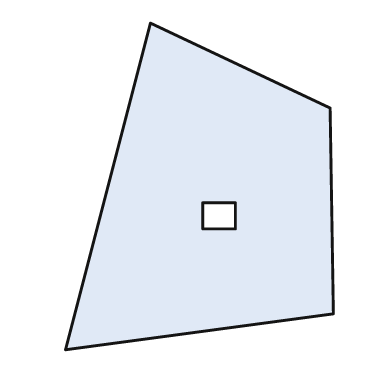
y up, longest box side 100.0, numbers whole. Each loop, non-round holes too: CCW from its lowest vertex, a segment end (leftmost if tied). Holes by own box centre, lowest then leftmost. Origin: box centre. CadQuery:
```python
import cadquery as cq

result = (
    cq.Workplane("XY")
    .moveTo(-41.0, -50.0)
    .lineTo(41.0, -39.0)
    .lineTo(40.0, 24.0)
    .lineTo(-15.0, 50.0)
    .close()
    .moveTo(1.0, -13.0)
    .lineTo(11.0, -13.0)
    .lineTo(11.0, -5.0)
    .lineTo(1.0, -5.0)
    .close()
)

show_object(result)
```